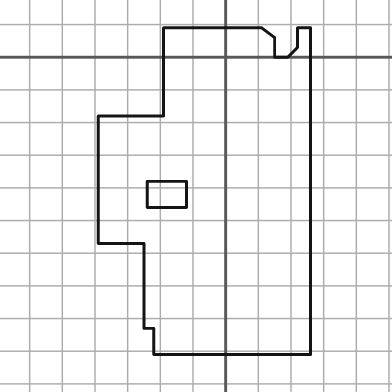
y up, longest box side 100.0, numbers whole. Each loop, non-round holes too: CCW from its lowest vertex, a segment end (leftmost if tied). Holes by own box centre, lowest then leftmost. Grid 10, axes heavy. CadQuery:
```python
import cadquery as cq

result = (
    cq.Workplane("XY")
    .moveTo(-22.0, -91.0)
    .lineTo(26.0, -91.0)
    .lineTo(26.0, 9.0)
    .lineTo(22.0, 9.0)
    .lineTo(22.0, 3.0)
    .lineTo(19.0, 0.0)
    .lineTo(15.0, 0.0)
    .lineTo(15.0, 6.0)
    .lineTo(11.0, 9.0)
    .lineTo(-19.0, 9.0)
    .lineTo(-19.0, -18.0)
    .lineTo(-39.0, -18.0)
    .lineTo(-39.0, -57.0)
    .lineTo(-25.0, -57.0)
    .lineTo(-25.0, -83.0)
    .lineTo(-22.0, -83.0)
    .close()
    .moveTo(-24.0, -46.0)
    .lineTo(-12.0, -46.0)
    .lineTo(-12.0, -38.0)
    .lineTo(-24.0, -38.0)
    .close()
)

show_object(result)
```